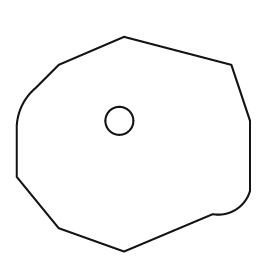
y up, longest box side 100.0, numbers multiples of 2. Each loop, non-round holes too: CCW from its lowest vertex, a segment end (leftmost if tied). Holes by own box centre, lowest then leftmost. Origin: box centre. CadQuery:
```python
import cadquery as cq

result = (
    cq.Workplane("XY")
    .moveTo(-4.0, -46.0)
    .lineTo(34.0, -30.0)
    .threePointArc((44.0, -28.0), (50.0, -20.0))
    .lineTo(50.0, 10.0)
    .lineTo(42.0, 34.0)
    .lineTo(-4.0, 46.0)
    .lineTo(-32.0, 34.0)
    .lineTo(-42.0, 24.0)
    .threePointArc((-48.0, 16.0), (-50.0, 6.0))
    .lineTo(-50.0, -14.0)
    .lineTo(-32.0, -36.0)
    .close()
    .moveTo(-6.0, 10.0)
    .circle(6.0)
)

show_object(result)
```